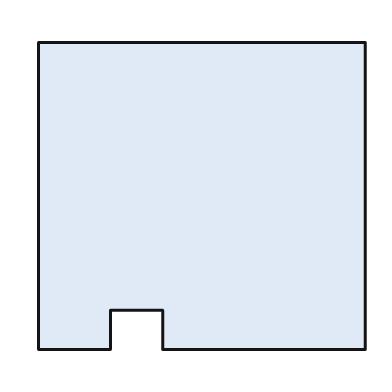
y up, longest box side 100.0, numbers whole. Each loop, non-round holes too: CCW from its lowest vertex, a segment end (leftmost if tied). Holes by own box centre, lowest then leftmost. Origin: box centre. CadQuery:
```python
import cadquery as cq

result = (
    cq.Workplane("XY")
    .moveTo(-50.0, -47.0)
    .lineTo(-28.0, -47.0)
    .lineTo(-28.0, -35.0)
    .lineTo(-12.0, -35.0)
    .lineTo(-12.0, -47.0)
    .lineTo(50.0, -47.0)
    .lineTo(50.0, 47.0)
    .lineTo(-50.0, 47.0)
    .close()
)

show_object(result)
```